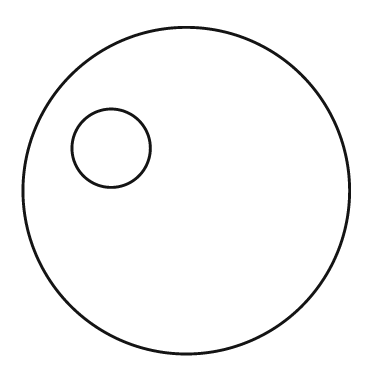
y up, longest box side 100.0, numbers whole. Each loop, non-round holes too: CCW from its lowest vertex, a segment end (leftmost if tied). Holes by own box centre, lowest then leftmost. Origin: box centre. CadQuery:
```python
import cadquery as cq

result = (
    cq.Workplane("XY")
    .moveTo(0.0, 0.0)
    .circle(50.0)
    .moveTo(-23.0, 13.0)
    .circle(12.0)
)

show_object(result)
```